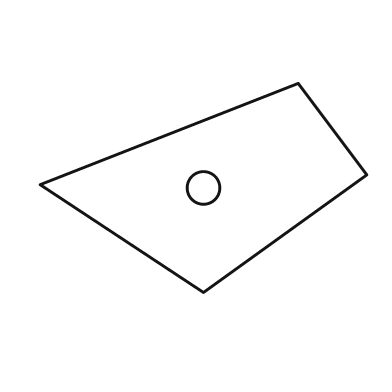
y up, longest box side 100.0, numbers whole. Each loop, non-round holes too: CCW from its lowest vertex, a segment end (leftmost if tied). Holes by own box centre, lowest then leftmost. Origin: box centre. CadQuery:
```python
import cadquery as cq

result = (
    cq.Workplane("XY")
    .moveTo(0.0, -32.0)
    .lineTo(50.0, 4.0)
    .lineTo(29.0, 32.0)
    .lineTo(-50.0, 1.0)
    .close()
    .moveTo(0.0, 0.0)
    .circle(5.0)
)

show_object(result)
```